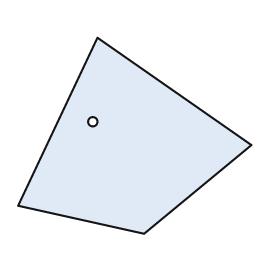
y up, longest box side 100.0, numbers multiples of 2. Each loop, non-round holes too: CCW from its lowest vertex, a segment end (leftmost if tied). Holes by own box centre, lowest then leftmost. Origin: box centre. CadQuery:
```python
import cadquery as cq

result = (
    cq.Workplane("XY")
    .moveTo(4.0, -42.0)
    .lineTo(50.0, -4.0)
    .lineTo(-16.0, 42.0)
    .lineTo(-50.0, -30.0)
    .close()
    .moveTo(-18.0, 6.0)
    .circle(2.0)
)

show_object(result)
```